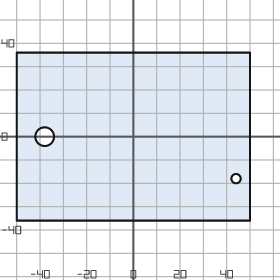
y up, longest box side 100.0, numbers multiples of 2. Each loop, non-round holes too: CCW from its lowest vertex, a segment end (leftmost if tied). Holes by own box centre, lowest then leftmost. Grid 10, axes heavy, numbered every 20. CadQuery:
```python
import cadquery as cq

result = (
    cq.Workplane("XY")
    .moveTo(-50.0, -36.0)
    .lineTo(50.0, -36.0)
    .lineTo(50.0, 36.0)
    .lineTo(-50.0, 36.0)
    .close()
    .moveTo(44.0, -18.0)
    .circle(2.0)
    .moveTo(-38.0, 0.0)
    .circle(4.0)
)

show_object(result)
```